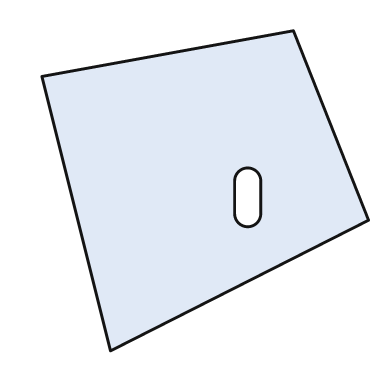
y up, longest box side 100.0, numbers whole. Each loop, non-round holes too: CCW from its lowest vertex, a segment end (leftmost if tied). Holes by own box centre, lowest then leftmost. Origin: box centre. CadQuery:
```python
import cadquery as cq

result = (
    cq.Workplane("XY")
    .moveTo(-29.0, -49.0)
    .lineTo(50.0, -9.0)
    .lineTo(27.0, 49.0)
    .lineTo(-50.0, 35.0)
    .close()
    .moveTo(9.0, -7.0)
    .threePointArc((13.0, -11.0), (17.0, -7.0))
    .lineTo(17.0, 3.0)
    .threePointArc((13.0, 7.0), (9.0, 3.0))
    .close()
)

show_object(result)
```